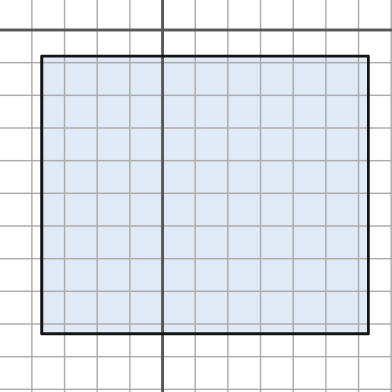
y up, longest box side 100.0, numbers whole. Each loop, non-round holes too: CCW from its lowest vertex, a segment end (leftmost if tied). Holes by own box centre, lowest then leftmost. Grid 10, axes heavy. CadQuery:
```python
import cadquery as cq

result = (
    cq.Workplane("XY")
    .moveTo(-37.0, -93.0)
    .lineTo(63.0, -93.0)
    .lineTo(63.0, -8.0)
    .lineTo(-37.0, -8.0)
    .close()
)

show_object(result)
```